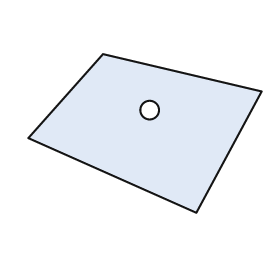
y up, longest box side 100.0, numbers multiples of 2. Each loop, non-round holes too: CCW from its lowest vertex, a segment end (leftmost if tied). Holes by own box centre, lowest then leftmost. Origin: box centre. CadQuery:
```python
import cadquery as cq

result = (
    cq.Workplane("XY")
    .moveTo(22.0, -34.0)
    .lineTo(50.0, 18.0)
    .lineTo(-18.0, 34.0)
    .lineTo(-50.0, -2.0)
    .close()
    .moveTo(2.0, 10.0)
    .circle(4.0)
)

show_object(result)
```